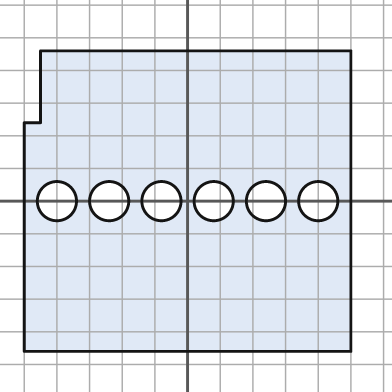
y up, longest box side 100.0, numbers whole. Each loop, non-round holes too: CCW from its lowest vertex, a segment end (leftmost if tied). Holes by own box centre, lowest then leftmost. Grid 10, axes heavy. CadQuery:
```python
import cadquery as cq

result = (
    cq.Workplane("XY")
    .moveTo(-50.0, -46.0)
    .lineTo(50.0, -46.0)
    .lineTo(50.0, 46.0)
    .lineTo(-45.0, 46.0)
    .lineTo(-45.0, 24.0)
    .lineTo(-50.0, 24.0)
    .close()
    .moveTo(-40.0, 0.0)
    .circle(6.0)
    .moveTo(-24.0, 0.0)
    .circle(6.0)
    .moveTo(-8.0, 0.0)
    .circle(6.0)
    .moveTo(8.0, 0.0)
    .circle(6.0)
    .moveTo(24.0, 0.0)
    .circle(6.0)
    .moveTo(40.0, 0.0)
    .circle(6.0)
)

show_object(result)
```